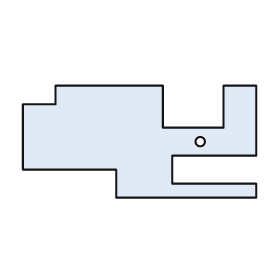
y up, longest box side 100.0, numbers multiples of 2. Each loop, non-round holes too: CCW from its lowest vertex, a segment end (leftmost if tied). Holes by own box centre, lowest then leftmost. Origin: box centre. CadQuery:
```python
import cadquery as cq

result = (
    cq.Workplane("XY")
    .moveTo(-10.0, -24.0)
    .lineTo(50.0, -24.0)
    .lineTo(50.0, -18.0)
    .lineTo(14.0, -18.0)
    .lineTo(14.0, -6.0)
    .lineTo(50.0, -6.0)
    .lineTo(50.0, 24.0)
    .lineTo(36.0, 24.0)
    .lineTo(36.0, 6.0)
    .lineTo(10.0, 6.0)
    .lineTo(10.0, 24.0)
    .lineTo(-36.0, 24.0)
    .lineTo(-36.0, 16.0)
    .lineTo(-50.0, 16.0)
    .lineTo(-50.0, -12.0)
    .lineTo(-10.0, -12.0)
    .close()
    .moveTo(26.0, 0.0)
    .circle(2.0)
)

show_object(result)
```